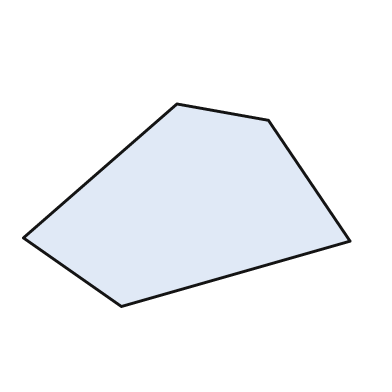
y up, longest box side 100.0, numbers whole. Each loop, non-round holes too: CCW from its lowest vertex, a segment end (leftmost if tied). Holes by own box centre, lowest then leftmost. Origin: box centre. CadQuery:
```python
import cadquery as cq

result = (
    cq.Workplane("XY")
    .moveTo(-20.0, -31.0)
    .lineTo(50.0, -11.0)
    .lineTo(25.0, 26.0)
    .lineTo(-3.0, 31.0)
    .lineTo(-50.0, -10.0)
    .close()
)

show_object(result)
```